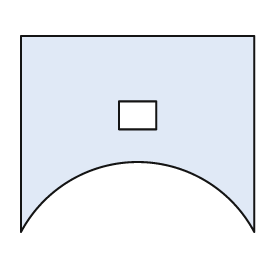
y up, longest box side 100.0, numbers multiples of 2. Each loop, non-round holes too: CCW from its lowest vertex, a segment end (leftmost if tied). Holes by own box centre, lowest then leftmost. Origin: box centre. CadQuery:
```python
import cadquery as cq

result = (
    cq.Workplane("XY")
    .moveTo(-50.0, -42.0)
    .threePointArc((0.0, -12.0), (50.0, -42.0))
    .lineTo(50.0, 42.0)
    .lineTo(-50.0, 42.0)
    .close()
    .moveTo(-8.0, 2.0)
    .lineTo(8.0, 2.0)
    .lineTo(8.0, 14.0)
    .lineTo(-8.0, 14.0)
    .close()
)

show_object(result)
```